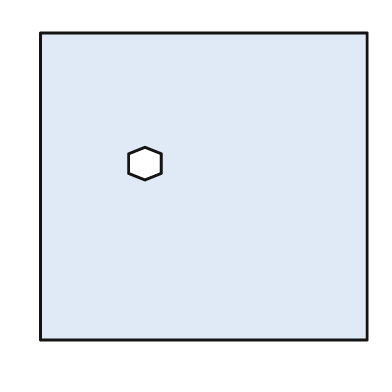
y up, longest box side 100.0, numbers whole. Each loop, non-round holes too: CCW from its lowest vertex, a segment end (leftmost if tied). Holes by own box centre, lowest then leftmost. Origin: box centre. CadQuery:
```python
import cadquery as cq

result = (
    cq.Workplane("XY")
    .moveTo(-50.0, -47.0)
    .lineTo(50.0, -47.0)
    .lineTo(50.0, 47.0)
    .lineTo(-50.0, 47.0)
    .close()
    .moveTo(-18.0, 2.0)
    .lineTo(-13.0, 4.0)
    .lineTo(-13.0, 10.0)
    .lineTo(-18.0, 12.0)
    .lineTo(-23.0, 10.0)
    .lineTo(-23.0, 4.0)
    .close()
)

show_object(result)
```